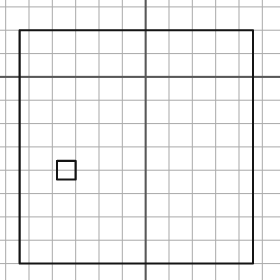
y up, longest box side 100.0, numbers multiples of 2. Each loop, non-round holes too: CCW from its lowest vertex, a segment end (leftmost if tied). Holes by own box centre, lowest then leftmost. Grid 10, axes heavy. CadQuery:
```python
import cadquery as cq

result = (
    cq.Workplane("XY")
    .moveTo(-54.0, -80.0)
    .lineTo(46.0, -80.0)
    .lineTo(46.0, 20.0)
    .lineTo(-54.0, 20.0)
    .close()
    .moveTo(-38.0, -44.0)
    .lineTo(-30.0, -44.0)
    .lineTo(-30.0, -36.0)
    .lineTo(-38.0, -36.0)
    .close()
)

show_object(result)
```